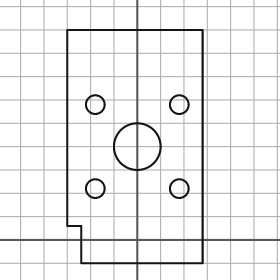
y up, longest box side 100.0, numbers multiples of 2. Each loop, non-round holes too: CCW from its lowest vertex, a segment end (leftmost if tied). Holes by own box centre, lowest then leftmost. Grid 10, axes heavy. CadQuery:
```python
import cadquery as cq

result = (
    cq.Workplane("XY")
    .moveTo(-24.0, -10.0)
    .lineTo(28.0, -10.0)
    .lineTo(28.0, 90.0)
    .lineTo(-30.0, 90.0)
    .lineTo(-30.0, 6.0)
    .lineTo(-24.0, 6.0)
    .close()
    .moveTo(-18.0, 22.0)
    .circle(4.0)
    .moveTo(18.0, 22.0)
    .circle(4.0)
    .moveTo(0.0, 40.0)
    .circle(10.0)
    .moveTo(-18.0, 58.0)
    .circle(4.0)
    .moveTo(18.0, 58.0)
    .circle(4.0)
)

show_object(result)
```